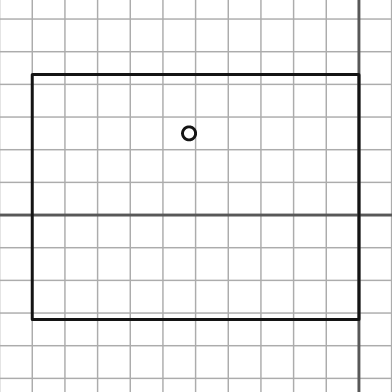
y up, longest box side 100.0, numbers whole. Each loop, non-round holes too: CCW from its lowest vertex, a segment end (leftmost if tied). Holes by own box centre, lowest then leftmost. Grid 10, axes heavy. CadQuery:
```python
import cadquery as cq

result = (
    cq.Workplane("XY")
    .moveTo(-100.0, -32.0)
    .lineTo(0.0, -32.0)
    .lineTo(0.0, 43.0)
    .lineTo(-100.0, 43.0)
    .close()
    .moveTo(-52.0, 25.0)
    .circle(2.0)
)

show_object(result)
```